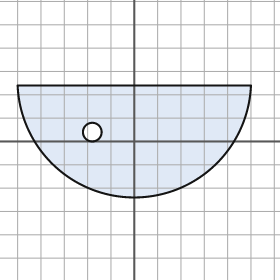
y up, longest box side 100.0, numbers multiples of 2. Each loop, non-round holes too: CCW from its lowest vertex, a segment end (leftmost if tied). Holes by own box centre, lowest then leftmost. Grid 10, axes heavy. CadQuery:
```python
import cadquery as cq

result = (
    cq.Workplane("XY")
    .moveTo(-50.0, 24.0)
    .threePointArc((0.0, -24.0), (50.0, 24.0))
    .close()
    .moveTo(-18.0, 4.0)
    .circle(4.0)
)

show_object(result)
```